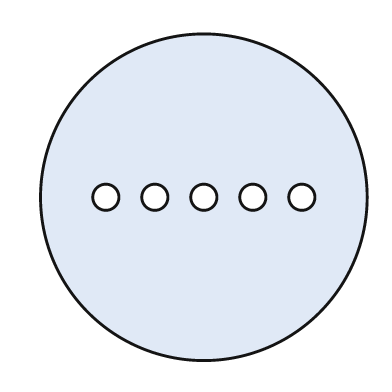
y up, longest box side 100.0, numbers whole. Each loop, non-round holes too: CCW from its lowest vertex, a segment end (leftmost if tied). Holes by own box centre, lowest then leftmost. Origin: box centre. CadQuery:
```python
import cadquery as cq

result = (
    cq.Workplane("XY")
    .moveTo(0.0, 0.0)
    .circle(50.0)
    .moveTo(-30.0, 0.0)
    .circle(4.0)
    .moveTo(-15.0, 0.0)
    .circle(4.0)
    .moveTo(0.0, 0.0)
    .circle(4.0)
    .moveTo(15.0, 0.0)
    .circle(4.0)
    .moveTo(30.0, 0.0)
    .circle(4.0)
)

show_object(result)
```